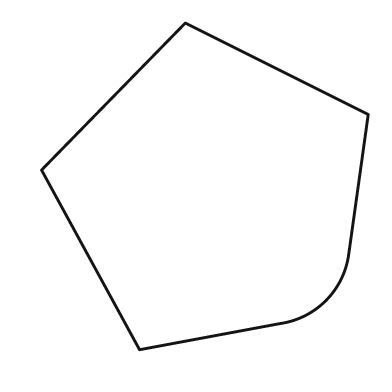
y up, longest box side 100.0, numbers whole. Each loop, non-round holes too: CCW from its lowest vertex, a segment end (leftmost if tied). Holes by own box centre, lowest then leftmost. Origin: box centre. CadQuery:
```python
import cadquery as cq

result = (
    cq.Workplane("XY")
    .moveTo(-20.0, -50.0)
    .lineTo(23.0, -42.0)
    .threePointArc((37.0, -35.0), (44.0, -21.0))
    .lineTo(50.0, 22.0)
    .lineTo(-6.0, 50.0)
    .lineTo(-50.0, 5.0)
    .close()
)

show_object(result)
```